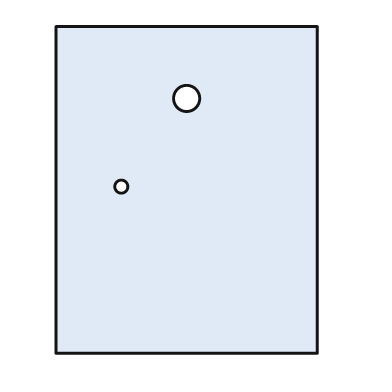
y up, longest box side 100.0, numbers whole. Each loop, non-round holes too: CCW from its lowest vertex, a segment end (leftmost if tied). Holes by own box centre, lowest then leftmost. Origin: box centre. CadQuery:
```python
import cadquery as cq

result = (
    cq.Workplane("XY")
    .moveTo(-40.0, -50.0)
    .lineTo(40.0, -50.0)
    .lineTo(40.0, 50.0)
    .lineTo(-40.0, 50.0)
    .close()
    .moveTo(-20.0, 1.0)
    .circle(2.0)
    .moveTo(0.0, 28.0)
    .circle(4.0)
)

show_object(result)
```